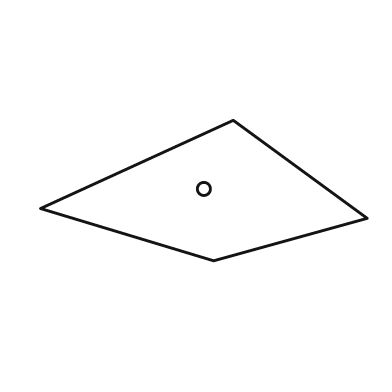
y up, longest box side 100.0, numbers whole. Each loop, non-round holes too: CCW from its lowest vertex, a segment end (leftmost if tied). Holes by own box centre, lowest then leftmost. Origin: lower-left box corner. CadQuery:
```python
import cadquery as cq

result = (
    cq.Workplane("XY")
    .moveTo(53.0, 0.0)
    .lineTo(100.0, 13.0)
    .lineTo(59.0, 43.0)
    .lineTo(0.0, 16.0)
    .close()
    .moveTo(50.0, 22.0)
    .circle(2.0)
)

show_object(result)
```